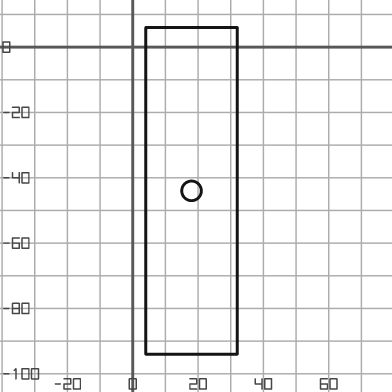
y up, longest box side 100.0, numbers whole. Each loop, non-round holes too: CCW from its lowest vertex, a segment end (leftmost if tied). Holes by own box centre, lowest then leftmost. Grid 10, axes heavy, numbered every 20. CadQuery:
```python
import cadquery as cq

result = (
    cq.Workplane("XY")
    .moveTo(4.0, -94.0)
    .lineTo(32.0, -94.0)
    .lineTo(32.0, 6.0)
    .lineTo(4.0, 6.0)
    .close()
    .moveTo(18.0, -44.0)
    .circle(3.0)
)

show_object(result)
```